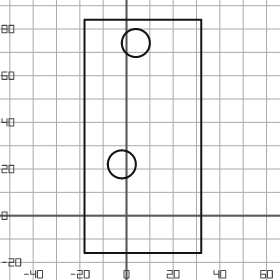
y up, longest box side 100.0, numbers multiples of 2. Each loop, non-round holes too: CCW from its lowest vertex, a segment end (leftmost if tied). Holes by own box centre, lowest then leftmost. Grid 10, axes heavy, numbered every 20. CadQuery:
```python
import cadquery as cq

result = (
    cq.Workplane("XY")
    .moveTo(-18.0, -16.0)
    .lineTo(32.0, -16.0)
    .lineTo(32.0, 84.0)
    .lineTo(-18.0, 84.0)
    .close()
    .moveTo(-2.0, 22.0)
    .circle(6.0)
    .moveTo(4.0, 74.0)
    .circle(6.0)
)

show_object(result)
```